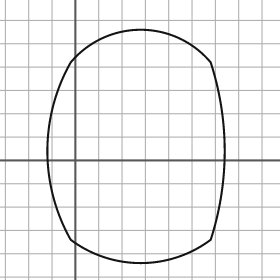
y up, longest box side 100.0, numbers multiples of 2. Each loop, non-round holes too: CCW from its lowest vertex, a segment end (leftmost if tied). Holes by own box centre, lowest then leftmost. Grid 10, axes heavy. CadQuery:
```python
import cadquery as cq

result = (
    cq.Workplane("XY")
    .moveTo(-2.0, -34.0)
    .threePointArc((28.0, -44.0), (58.0, -34.0))
    .threePointArc((64.0, 4.0), (58.0, 42.0))
    .threePointArc((28.0, 56.0), (-2.0, 42.0))
    .threePointArc((-12.0, 4.0), (-2.0, -34.0))
    .close()
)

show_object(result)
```